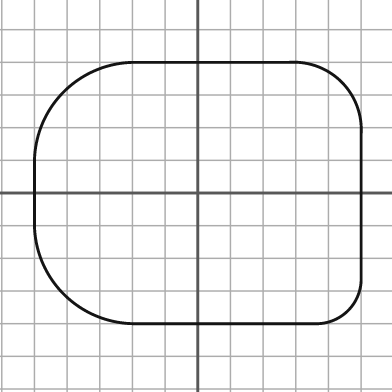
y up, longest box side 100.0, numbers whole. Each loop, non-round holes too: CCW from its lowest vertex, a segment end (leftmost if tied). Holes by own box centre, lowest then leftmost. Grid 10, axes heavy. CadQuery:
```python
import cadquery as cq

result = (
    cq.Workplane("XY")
    .moveTo(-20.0, -40.0)
    .lineTo(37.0, -40.0)
    .threePointArc((46.0, -36.0), (50.0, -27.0))
    .lineTo(50.0, 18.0)
    .threePointArc((44.0, 34.0), (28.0, 40.0))
    .lineTo(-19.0, 40.0)
    .threePointArc((-41.0, 31.0), (-50.0, 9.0))
    .lineTo(-50.0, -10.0)
    .threePointArc((-41.0, -31.0), (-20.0, -40.0))
    .close()
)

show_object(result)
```